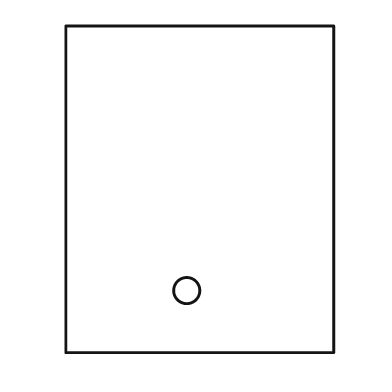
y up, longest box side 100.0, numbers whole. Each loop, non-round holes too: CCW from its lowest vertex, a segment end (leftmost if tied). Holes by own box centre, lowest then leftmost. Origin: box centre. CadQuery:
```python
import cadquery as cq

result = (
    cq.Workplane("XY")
    .moveTo(-41.0, -50.0)
    .lineTo(41.0, -50.0)
    .lineTo(41.0, 50.0)
    .lineTo(-41.0, 50.0)
    .close()
    .moveTo(-4.0, -31.0)
    .circle(4.0)
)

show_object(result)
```